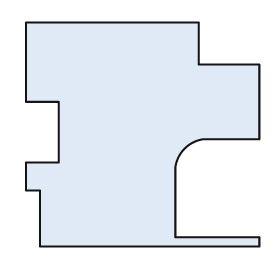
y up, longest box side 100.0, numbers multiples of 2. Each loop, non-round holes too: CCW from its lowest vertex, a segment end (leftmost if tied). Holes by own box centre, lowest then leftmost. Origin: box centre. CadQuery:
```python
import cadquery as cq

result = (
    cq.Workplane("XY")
    .moveTo(-44.0, -48.0)
    .lineTo(50.0, -48.0)
    .lineTo(50.0, -44.0)
    .lineTo(14.0, -44.0)
    .lineTo(14.0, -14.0)
    .threePointArc((18.0, -6.0), (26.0, -2.0))
    .lineTo(50.0, -2.0)
    .lineTo(50.0, 30.0)
    .lineTo(24.0, 30.0)
    .lineTo(24.0, 48.0)
    .lineTo(-50.0, 48.0)
    .lineTo(-50.0, 14.0)
    .lineTo(-36.0, 14.0)
    .lineTo(-36.0, -12.0)
    .lineTo(-50.0, -12.0)
    .lineTo(-50.0, -24.0)
    .lineTo(-44.0, -24.0)
    .close()
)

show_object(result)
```